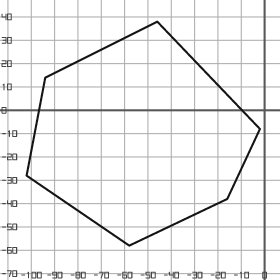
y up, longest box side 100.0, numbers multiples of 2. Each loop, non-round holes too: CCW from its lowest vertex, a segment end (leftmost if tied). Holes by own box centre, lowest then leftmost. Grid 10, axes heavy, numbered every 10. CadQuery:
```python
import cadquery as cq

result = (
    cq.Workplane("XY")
    .moveTo(-58.0, -58.0)
    .lineTo(-16.0, -38.0)
    .lineTo(-2.0, -8.0)
    .lineTo(-46.0, 38.0)
    .lineTo(-94.0, 14.0)
    .lineTo(-102.0, -28.0)
    .close()
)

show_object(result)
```